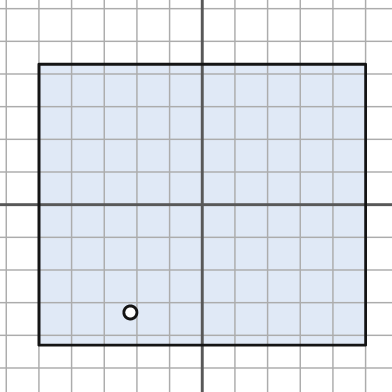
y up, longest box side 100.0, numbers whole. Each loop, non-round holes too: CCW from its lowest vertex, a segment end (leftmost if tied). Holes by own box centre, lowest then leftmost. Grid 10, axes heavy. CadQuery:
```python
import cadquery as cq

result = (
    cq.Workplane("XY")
    .moveTo(-50.0, -43.0)
    .lineTo(50.0, -43.0)
    .lineTo(50.0, 43.0)
    .lineTo(-50.0, 43.0)
    .close()
    .moveTo(-22.0, -33.0)
    .circle(2.0)
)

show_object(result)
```